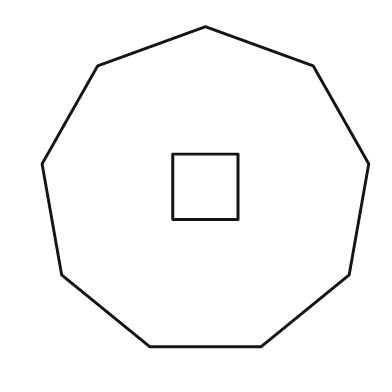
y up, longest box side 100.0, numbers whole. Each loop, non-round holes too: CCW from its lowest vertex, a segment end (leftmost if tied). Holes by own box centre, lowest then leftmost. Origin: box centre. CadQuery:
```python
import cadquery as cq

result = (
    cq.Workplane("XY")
    .moveTo(-17.0, -49.0)
    .lineTo(17.0, -49.0)
    .lineTo(44.0, -27.0)
    .lineTo(50.0, 7.0)
    .lineTo(33.0, 37.0)
    .lineTo(0.0, 49.0)
    .lineTo(-33.0, 37.0)
    .lineTo(-50.0, 7.0)
    .lineTo(-44.0, -27.0)
    .close()
    .moveTo(-10.0, -10.0)
    .lineTo(10.0, -10.0)
    .lineTo(10.0, 10.0)
    .lineTo(-10.0, 10.0)
    .close()
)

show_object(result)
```